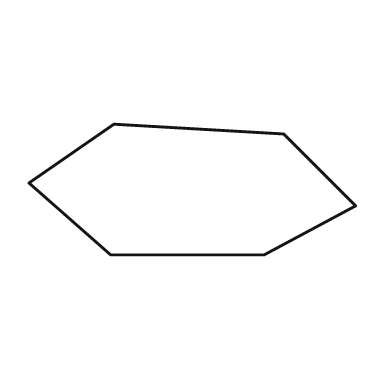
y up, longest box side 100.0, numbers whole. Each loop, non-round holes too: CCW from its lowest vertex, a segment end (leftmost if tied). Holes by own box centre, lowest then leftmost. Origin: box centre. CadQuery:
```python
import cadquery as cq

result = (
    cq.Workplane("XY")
    .moveTo(-25.0, -20.0)
    .lineTo(22.0, -20.0)
    .lineTo(50.0, -5.0)
    .lineTo(28.0, 17.0)
    .lineTo(-24.0, 20.0)
    .lineTo(-50.0, 2.0)
    .close()
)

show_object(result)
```